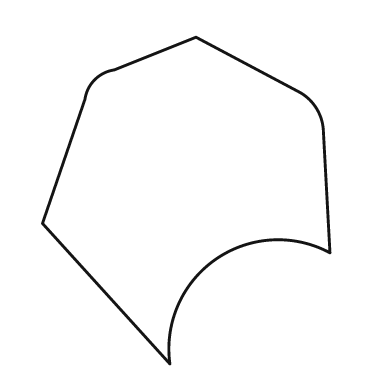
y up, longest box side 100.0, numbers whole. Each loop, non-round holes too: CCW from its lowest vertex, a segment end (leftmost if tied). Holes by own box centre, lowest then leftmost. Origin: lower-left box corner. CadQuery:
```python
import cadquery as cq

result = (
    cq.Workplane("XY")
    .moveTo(39.0, 0.0)
    .threePointArc((53.0, 32.0), (88.0, 34.0))
    .lineTo(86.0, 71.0)
    .threePointArc((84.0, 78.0), (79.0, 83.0))
    .lineTo(47.0, 100.0)
    .lineTo(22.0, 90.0)
    .threePointArc((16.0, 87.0), (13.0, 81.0))
    .lineTo(0.0, 43.0)
    .close()
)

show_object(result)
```